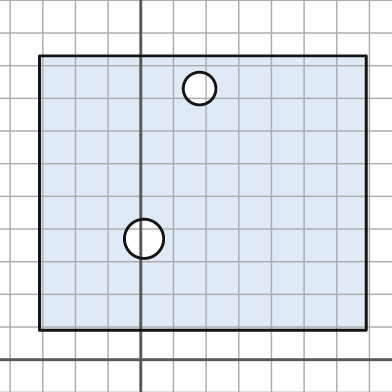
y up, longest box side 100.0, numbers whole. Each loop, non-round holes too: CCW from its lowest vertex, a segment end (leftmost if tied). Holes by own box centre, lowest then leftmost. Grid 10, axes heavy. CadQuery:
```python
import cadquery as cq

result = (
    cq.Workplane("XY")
    .moveTo(-31.0, 9.0)
    .lineTo(69.0, 9.0)
    .lineTo(69.0, 93.0)
    .lineTo(-31.0, 93.0)
    .close()
    .moveTo(1.0, 37.0)
    .circle(6.0)
    .moveTo(18.0, 83.0)
    .circle(5.0)
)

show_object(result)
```